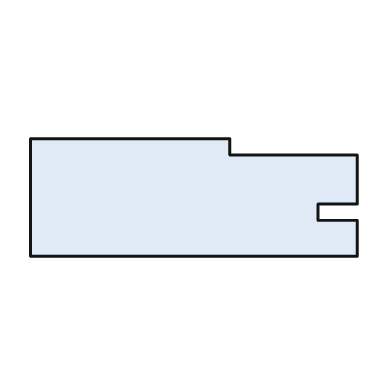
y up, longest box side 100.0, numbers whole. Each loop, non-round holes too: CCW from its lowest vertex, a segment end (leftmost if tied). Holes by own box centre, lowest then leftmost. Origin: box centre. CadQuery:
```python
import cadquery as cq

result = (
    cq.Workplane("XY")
    .moveTo(-50.0, -18.0)
    .lineTo(50.0, -18.0)
    .lineTo(50.0, -7.0)
    .lineTo(38.0, -7.0)
    .lineTo(38.0, -2.0)
    .lineTo(50.0, -2.0)
    .lineTo(50.0, 13.0)
    .lineTo(11.0, 13.0)
    .lineTo(11.0, 18.0)
    .lineTo(-50.0, 18.0)
    .close()
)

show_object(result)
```